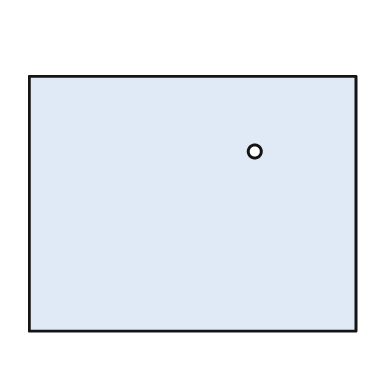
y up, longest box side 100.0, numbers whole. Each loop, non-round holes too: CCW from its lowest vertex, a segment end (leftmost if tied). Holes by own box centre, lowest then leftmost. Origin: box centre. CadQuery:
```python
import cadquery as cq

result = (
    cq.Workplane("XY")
    .moveTo(-50.0, -39.0)
    .lineTo(50.0, -39.0)
    .lineTo(50.0, 39.0)
    .lineTo(-50.0, 39.0)
    .close()
    .moveTo(19.0, 16.0)
    .circle(2.0)
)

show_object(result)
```